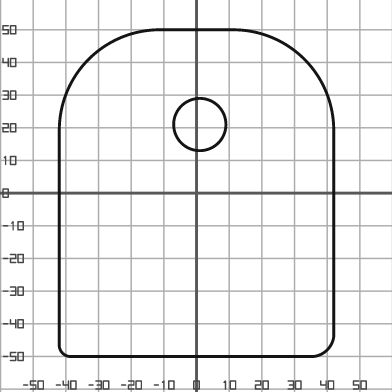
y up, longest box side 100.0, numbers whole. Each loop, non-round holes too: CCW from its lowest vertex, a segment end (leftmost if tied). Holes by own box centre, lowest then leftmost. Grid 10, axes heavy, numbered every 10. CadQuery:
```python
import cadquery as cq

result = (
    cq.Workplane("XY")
    .moveTo(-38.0, -50.0)
    .lineTo(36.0, -50.0)
    .threePointArc((40.0, -48.0), (42.0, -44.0))
    .lineTo(42.0, 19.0)
    .threePointArc((33.0, 41.0), (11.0, 50.0))
    .lineTo(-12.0, 50.0)
    .threePointArc((-33.0, 41.0), (-42.0, 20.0))
    .lineTo(-42.0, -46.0)
    .threePointArc((-41.0, -49.0), (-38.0, -50.0))
    .close()
    .moveTo(1.0, 21.0)
    .circle(8.0)
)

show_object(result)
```